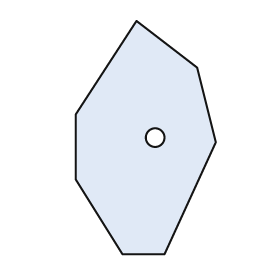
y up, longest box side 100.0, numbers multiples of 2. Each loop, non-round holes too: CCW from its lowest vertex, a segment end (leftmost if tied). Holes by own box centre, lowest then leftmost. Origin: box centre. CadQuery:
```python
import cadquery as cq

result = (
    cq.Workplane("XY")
    .moveTo(-10.0, -50.0)
    .lineTo(8.0, -50.0)
    .lineTo(30.0, -2.0)
    .lineTo(22.0, 30.0)
    .lineTo(-4.0, 50.0)
    .lineTo(-30.0, 10.0)
    .lineTo(-30.0, -18.0)
    .close()
    .moveTo(4.0, 0.0)
    .circle(4.0)
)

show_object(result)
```